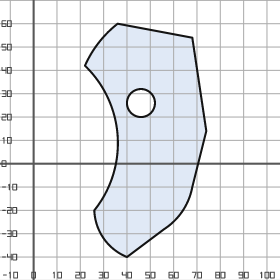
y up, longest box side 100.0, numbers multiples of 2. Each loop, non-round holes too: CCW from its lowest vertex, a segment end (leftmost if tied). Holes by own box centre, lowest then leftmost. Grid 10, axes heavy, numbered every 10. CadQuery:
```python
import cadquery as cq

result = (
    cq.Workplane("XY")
    .moveTo(40.0, -40.0)
    .lineTo(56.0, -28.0)
    .threePointArc((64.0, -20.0), (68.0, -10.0))
    .lineTo(74.0, 14.0)
    .lineTo(68.0, 54.0)
    .lineTo(36.0, 60.0)
    .threePointArc((28.0, 52.0), (22.0, 42.0))
    .threePointArc((36.0, 12.0), (26.0, -20.0))
    .threePointArc((30.0, -32.0), (40.0, -40.0))
    .close()
    .moveTo(46.0, 26.0)
    .circle(6.0)
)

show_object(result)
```